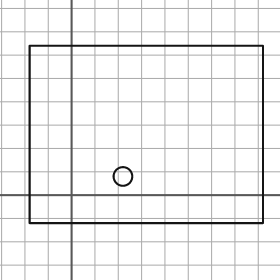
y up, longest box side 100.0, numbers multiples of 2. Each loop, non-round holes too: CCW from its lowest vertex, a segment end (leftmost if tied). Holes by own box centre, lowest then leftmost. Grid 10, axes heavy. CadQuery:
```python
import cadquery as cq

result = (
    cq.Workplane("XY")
    .moveTo(-18.0, -12.0)
    .lineTo(82.0, -12.0)
    .lineTo(82.0, 64.0)
    .lineTo(-18.0, 64.0)
    .close()
    .moveTo(22.0, 8.0)
    .circle(4.0)
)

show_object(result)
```